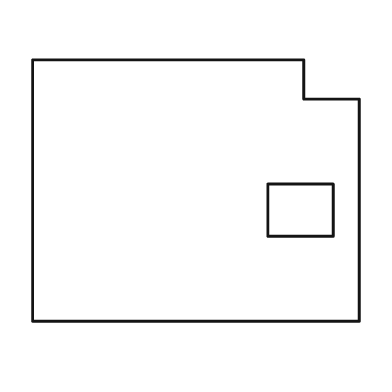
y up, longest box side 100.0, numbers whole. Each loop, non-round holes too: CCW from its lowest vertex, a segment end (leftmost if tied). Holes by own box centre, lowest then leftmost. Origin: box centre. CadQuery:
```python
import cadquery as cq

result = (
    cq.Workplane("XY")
    .moveTo(-50.0, -40.0)
    .lineTo(50.0, -40.0)
    .lineTo(50.0, 28.0)
    .lineTo(33.0, 28.0)
    .lineTo(33.0, 40.0)
    .lineTo(-50.0, 40.0)
    .close()
    .moveTo(22.0, -14.0)
    .lineTo(42.0, -14.0)
    .lineTo(42.0, 2.0)
    .lineTo(22.0, 2.0)
    .close()
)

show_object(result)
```